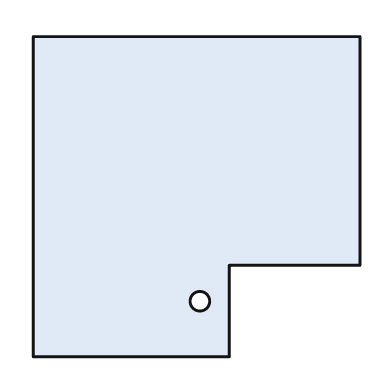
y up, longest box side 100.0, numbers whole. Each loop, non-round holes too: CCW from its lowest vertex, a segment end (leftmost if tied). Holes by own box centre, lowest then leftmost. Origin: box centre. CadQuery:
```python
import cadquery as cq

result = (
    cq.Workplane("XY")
    .moveTo(-50.0, -49.0)
    .lineTo(10.0, -49.0)
    .lineTo(10.0, -21.0)
    .lineTo(50.0, -21.0)
    .lineTo(50.0, 49.0)
    .lineTo(-50.0, 49.0)
    .close()
    .moveTo(1.0, -32.0)
    .circle(3.0)
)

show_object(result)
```